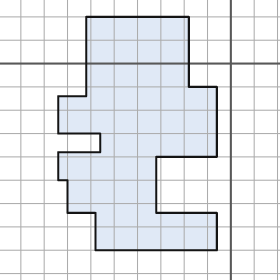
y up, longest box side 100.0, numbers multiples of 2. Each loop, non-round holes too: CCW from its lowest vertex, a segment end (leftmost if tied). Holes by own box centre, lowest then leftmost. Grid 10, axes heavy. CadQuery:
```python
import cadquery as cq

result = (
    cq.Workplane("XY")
    .moveTo(-58.0, -80.0)
    .lineTo(-6.0, -80.0)
    .lineTo(-6.0, -64.0)
    .lineTo(-32.0, -64.0)
    .lineTo(-32.0, -40.0)
    .lineTo(-6.0, -40.0)
    .lineTo(-6.0, -10.0)
    .lineTo(-18.0, -10.0)
    .lineTo(-18.0, 20.0)
    .lineTo(-62.0, 20.0)
    .lineTo(-62.0, -14.0)
    .lineTo(-74.0, -14.0)
    .lineTo(-74.0, -30.0)
    .lineTo(-56.0, -30.0)
    .lineTo(-56.0, -38.0)
    .lineTo(-74.0, -38.0)
    .lineTo(-74.0, -50.0)
    .lineTo(-70.0, -50.0)
    .lineTo(-70.0, -64.0)
    .lineTo(-58.0, -64.0)
    .close()
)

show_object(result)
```